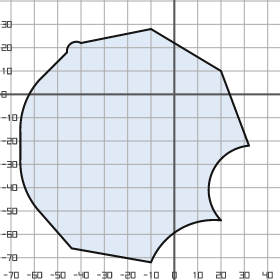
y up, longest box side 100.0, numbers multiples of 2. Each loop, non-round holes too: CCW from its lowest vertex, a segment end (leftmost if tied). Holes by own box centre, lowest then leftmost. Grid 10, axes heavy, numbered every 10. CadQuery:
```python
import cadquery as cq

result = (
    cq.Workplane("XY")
    .moveTo(-10.0, -72.0)
    .threePointArc((2.0, -58.0), (20.0, -54.0))
    .threePointArc((16.0, -34.0), (32.0, -22.0))
    .lineTo(20.0, 10.0)
    .lineTo(-10.0, 28.0)
    .lineTo(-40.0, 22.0)
    .threePointArc((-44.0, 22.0), (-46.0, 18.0))
    .lineTo(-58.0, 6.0)
    .threePointArc((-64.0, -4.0), (-66.0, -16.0))
    .lineTo(-66.0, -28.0)
    .threePointArc((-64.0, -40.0), (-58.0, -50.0))
    .lineTo(-44.0, -66.0)
    .close()
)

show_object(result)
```